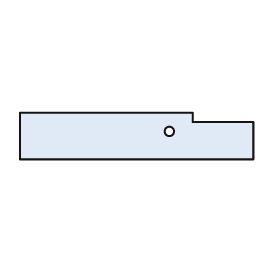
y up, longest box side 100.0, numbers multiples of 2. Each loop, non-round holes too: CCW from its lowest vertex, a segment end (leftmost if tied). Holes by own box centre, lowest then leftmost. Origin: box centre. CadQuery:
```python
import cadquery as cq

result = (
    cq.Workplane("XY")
    .moveTo(-50.0, -10.0)
    .lineTo(50.0, -10.0)
    .lineTo(50.0, 6.0)
    .lineTo(24.0, 6.0)
    .lineTo(24.0, 10.0)
    .lineTo(-50.0, 10.0)
    .close()
    .moveTo(14.0, 2.0)
    .circle(2.0)
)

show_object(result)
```